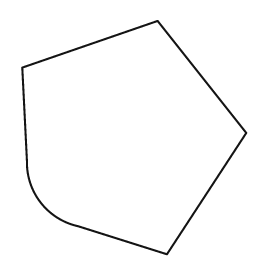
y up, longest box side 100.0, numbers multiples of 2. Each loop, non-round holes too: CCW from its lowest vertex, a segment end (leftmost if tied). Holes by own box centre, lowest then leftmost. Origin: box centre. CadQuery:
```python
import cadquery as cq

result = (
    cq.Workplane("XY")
    .moveTo(14.0, -50.0)
    .lineTo(48.0, 2.0)
    .lineTo(10.0, 50.0)
    .lineTo(-48.0, 30.0)
    .lineTo(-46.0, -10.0)
    .threePointArc((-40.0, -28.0), (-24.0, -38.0))
    .close()
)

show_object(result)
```